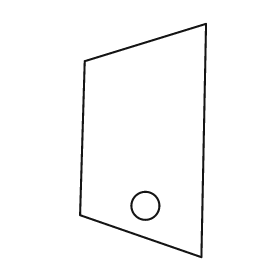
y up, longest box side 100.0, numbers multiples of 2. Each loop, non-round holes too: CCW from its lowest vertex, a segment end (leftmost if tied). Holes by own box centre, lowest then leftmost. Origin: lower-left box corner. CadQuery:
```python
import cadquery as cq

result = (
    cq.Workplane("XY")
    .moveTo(52.0, 0.0)
    .lineTo(54.0, 100.0)
    .lineTo(2.0, 84.0)
    .lineTo(0.0, 18.0)
    .close()
    .moveTo(28.0, 22.0)
    .circle(6.0)
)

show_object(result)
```